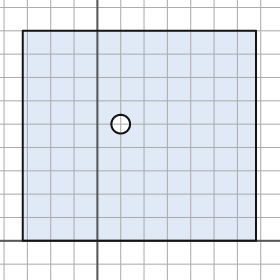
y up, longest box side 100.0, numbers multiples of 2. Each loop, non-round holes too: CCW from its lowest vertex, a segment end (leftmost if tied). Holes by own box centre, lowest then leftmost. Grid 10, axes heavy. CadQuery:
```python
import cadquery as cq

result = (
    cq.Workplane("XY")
    .moveTo(-32.0, 0.0)
    .lineTo(68.0, 0.0)
    .lineTo(68.0, 90.0)
    .lineTo(-32.0, 90.0)
    .close()
    .moveTo(10.0, 50.0)
    .circle(4.0)
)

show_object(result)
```